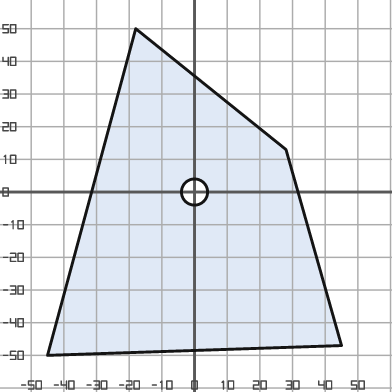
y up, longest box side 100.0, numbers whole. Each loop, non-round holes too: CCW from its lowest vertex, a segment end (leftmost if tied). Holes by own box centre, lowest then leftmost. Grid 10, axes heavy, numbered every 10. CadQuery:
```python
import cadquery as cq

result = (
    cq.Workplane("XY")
    .moveTo(-45.0, -50.0)
    .lineTo(45.0, -47.0)
    .lineTo(28.0, 13.0)
    .lineTo(-18.0, 50.0)
    .close()
    .moveTo(0.0, 0.0)
    .circle(4.0)
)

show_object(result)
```